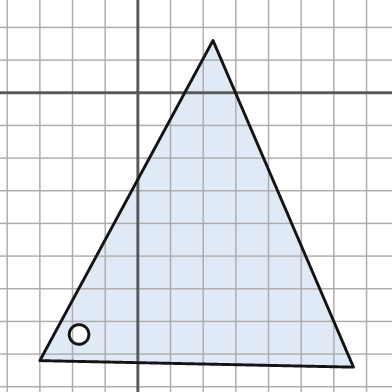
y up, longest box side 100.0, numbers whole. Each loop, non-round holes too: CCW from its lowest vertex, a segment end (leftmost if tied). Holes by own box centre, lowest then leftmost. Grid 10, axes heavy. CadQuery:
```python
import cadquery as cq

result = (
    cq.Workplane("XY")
    .moveTo(66.0, -84.0)
    .lineTo(23.0, 16.0)
    .lineTo(-30.0, -82.0)
    .close()
    .moveTo(-18.0, -74.0)
    .circle(3.0)
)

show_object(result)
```